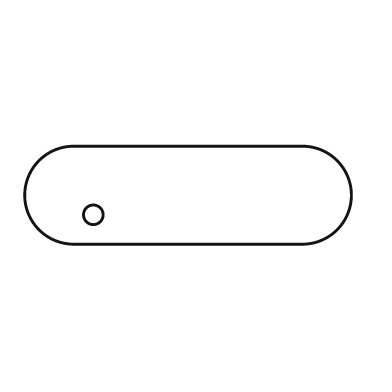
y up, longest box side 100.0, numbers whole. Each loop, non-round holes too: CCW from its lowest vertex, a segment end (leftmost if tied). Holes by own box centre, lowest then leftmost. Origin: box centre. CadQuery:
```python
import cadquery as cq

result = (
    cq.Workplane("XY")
    .moveTo(-35.0, -15.0)
    .lineTo(35.0, -15.0)
    .threePointArc((50.0, 0.0), (35.0, 15.0))
    .lineTo(-35.0, 15.0)
    .threePointArc((-50.0, 0.0), (-35.0, -15.0))
    .close()
    .moveTo(-29.0, -6.0)
    .circle(3.0)
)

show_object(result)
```